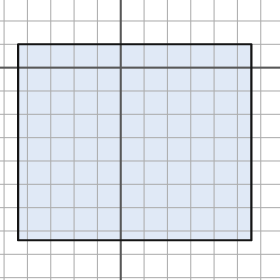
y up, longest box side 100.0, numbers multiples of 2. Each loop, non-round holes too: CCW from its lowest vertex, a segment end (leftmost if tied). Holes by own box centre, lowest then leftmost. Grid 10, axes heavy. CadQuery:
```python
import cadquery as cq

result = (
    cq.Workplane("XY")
    .moveTo(-44.0, -74.0)
    .lineTo(56.0, -74.0)
    .lineTo(56.0, 10.0)
    .lineTo(-44.0, 10.0)
    .close()
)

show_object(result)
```